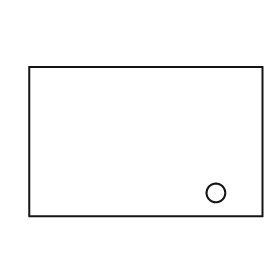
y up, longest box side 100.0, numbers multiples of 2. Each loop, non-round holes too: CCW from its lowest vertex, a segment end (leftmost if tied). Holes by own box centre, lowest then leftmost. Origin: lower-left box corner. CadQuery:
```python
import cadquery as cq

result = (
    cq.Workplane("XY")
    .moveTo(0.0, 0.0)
    .lineTo(100.0, 0.0)
    .lineTo(100.0, 64.0)
    .lineTo(0.0, 64.0)
    .close()
    .moveTo(80.0, 10.0)
    .circle(4.0)
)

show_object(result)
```